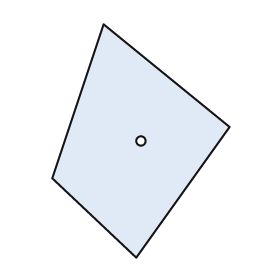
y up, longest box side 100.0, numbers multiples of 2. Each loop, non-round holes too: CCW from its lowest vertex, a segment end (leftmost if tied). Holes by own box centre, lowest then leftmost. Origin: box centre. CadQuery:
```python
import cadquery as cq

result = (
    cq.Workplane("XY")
    .moveTo(-2.0, -50.0)
    .lineTo(38.0, 6.0)
    .lineTo(-16.0, 50.0)
    .lineTo(-38.0, -16.0)
    .close()
    .moveTo(0.0, 0.0)
    .circle(2.0)
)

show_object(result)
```